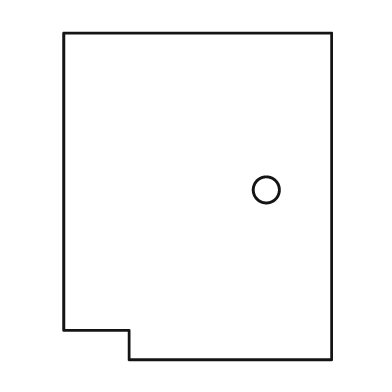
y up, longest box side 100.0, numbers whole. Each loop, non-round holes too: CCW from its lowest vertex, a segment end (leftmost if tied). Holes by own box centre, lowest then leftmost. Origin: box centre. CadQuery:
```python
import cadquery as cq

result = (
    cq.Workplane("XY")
    .moveTo(-21.0, -50.0)
    .lineTo(41.0, -50.0)
    .lineTo(41.0, 50.0)
    .lineTo(-41.0, 50.0)
    .lineTo(-41.0, -41.0)
    .lineTo(-21.0, -41.0)
    .close()
    .moveTo(21.0, 2.0)
    .circle(4.0)
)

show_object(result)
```